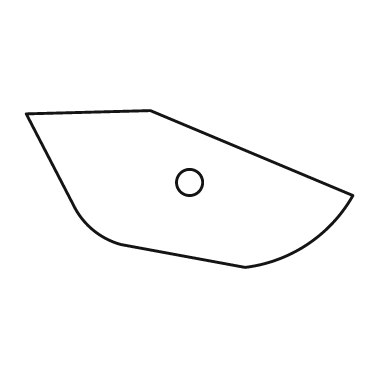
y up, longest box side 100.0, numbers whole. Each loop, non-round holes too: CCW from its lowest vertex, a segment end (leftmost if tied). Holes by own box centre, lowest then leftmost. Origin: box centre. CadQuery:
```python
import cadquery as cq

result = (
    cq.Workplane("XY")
    .moveTo(17.0, -24.0)
    .threePointArc((36.0, -17.0), (50.0, -2.0))
    .lineTo(-12.0, 24.0)
    .lineTo(-50.0, 23.0)
    .lineTo(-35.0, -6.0)
    .threePointArc((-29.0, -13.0), (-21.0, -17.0))
    .close()
    .moveTo(0.0, 2.0)
    .circle(4.0)
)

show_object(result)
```